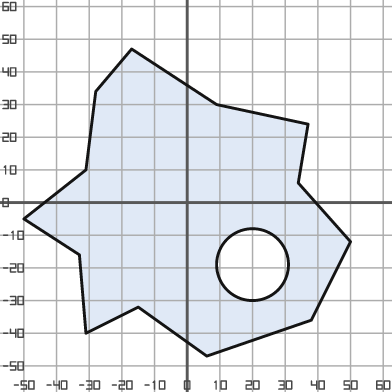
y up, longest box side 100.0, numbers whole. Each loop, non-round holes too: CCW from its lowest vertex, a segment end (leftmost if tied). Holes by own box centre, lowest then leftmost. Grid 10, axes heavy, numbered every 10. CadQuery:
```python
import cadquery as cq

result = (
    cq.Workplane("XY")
    .moveTo(6.0, -47.0)
    .lineTo(38.0, -36.0)
    .lineTo(50.0, -12.0)
    .lineTo(34.0, 6.0)
    .lineTo(37.0, 24.0)
    .lineTo(9.0, 30.0)
    .lineTo(-17.0, 47.0)
    .lineTo(-28.0, 34.0)
    .lineTo(-31.0, 10.0)
    .lineTo(-50.0, -5.0)
    .lineTo(-33.0, -16.0)
    .lineTo(-31.0, -40.0)
    .lineTo(-15.0, -32.0)
    .close()
    .moveTo(20.0, -19.0)
    .circle(11.0)
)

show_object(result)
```